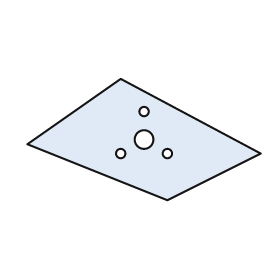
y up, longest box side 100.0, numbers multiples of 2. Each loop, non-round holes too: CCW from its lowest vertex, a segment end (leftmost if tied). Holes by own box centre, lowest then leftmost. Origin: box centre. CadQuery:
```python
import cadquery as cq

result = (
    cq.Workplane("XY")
    .moveTo(10.0, -26.0)
    .lineTo(50.0, -6.0)
    .lineTo(-10.0, 26.0)
    .lineTo(-50.0, -2.0)
    .close()
    .moveTo(-10.0, -6.0)
    .circle(2.0)
    .moveTo(10.0, -6.0)
    .circle(2.0)
    .moveTo(0.0, 0.0)
    .circle(4.0)
    .moveTo(0.0, 12.0)
    .circle(2.0)
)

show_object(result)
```